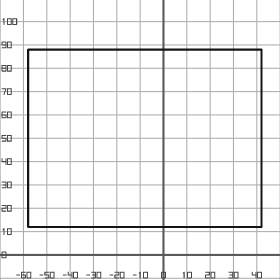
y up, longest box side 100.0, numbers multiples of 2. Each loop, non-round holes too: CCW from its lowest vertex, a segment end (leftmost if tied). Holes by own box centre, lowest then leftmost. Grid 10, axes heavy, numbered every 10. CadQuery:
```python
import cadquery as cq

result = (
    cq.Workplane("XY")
    .moveTo(-58.0, 12.0)
    .lineTo(42.0, 12.0)
    .lineTo(42.0, 88.0)
    .lineTo(-58.0, 88.0)
    .close()
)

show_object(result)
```